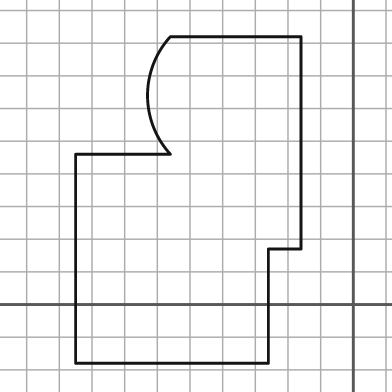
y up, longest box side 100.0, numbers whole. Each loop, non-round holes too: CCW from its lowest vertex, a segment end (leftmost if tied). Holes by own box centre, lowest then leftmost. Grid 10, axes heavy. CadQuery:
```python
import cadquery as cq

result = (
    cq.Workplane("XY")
    .moveTo(-85.0, -18.0)
    .lineTo(-26.0, -18.0)
    .lineTo(-26.0, 17.0)
    .lineTo(-16.0, 17.0)
    .lineTo(-16.0, 82.0)
    .lineTo(-56.0, 82.0)
    .threePointArc((-63.0, 64.0), (-56.0, 46.0))
    .lineTo(-85.0, 46.0)
    .close()
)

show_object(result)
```